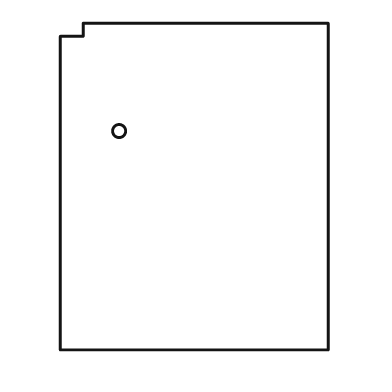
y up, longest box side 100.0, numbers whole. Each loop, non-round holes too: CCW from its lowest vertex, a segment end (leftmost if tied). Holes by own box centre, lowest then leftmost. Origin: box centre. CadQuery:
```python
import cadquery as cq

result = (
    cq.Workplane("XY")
    .moveTo(-41.0, -50.0)
    .lineTo(41.0, -50.0)
    .lineTo(41.0, 50.0)
    .lineTo(-34.0, 50.0)
    .lineTo(-34.0, 46.0)
    .lineTo(-41.0, 46.0)
    .close()
    .moveTo(-23.0, 17.0)
    .circle(2.0)
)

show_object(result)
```